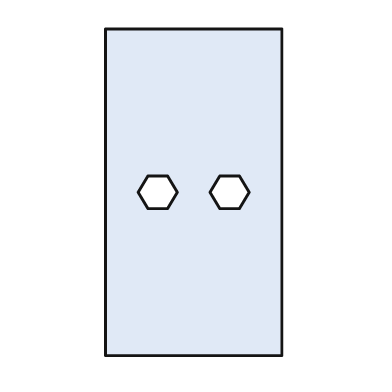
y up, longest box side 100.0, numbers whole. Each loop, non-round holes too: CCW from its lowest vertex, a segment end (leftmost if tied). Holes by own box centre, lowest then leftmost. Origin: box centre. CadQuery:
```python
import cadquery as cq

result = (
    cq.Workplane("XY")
    .moveTo(-27.0, -50.0)
    .lineTo(27.0, -50.0)
    .lineTo(27.0, 50.0)
    .lineTo(-27.0, 50.0)
    .close()
    .moveTo(-14.0, -5.0)
    .lineTo(-8.0, -5.0)
    .lineTo(-5.0, 0.0)
    .lineTo(-8.0, 5.0)
    .lineTo(-14.0, 5.0)
    .lineTo(-17.0, 0.0)
    .close()
    .moveTo(8.0, -5.0)
    .lineTo(14.0, -5.0)
    .lineTo(17.0, 0.0)
    .lineTo(14.0, 5.0)
    .lineTo(8.0, 5.0)
    .lineTo(5.0, 0.0)
    .close()
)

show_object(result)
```